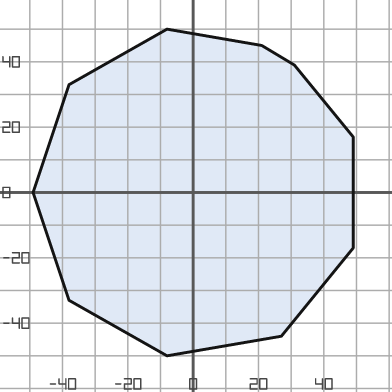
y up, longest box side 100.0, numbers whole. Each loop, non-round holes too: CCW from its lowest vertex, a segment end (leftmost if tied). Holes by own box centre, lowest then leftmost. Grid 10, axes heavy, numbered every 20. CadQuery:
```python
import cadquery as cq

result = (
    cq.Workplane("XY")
    .moveTo(-8.0, -50.0)
    .lineTo(27.0, -44.0)
    .lineTo(49.0, -17.0)
    .lineTo(49.0, 17.0)
    .lineTo(31.0, 39.0)
    .lineTo(21.0, 45.0)
    .lineTo(-8.0, 50.0)
    .lineTo(-38.0, 33.0)
    .lineTo(-49.0, 0.0)
    .lineTo(-38.0, -33.0)
    .close()
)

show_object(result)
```